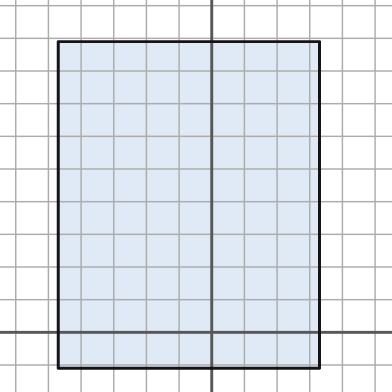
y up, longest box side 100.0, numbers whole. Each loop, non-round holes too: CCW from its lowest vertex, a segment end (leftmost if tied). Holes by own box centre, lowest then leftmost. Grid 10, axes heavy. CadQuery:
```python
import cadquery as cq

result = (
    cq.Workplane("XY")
    .moveTo(-47.0, -11.0)
    .lineTo(33.0, -11.0)
    .lineTo(33.0, 89.0)
    .lineTo(-47.0, 89.0)
    .close()
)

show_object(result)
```